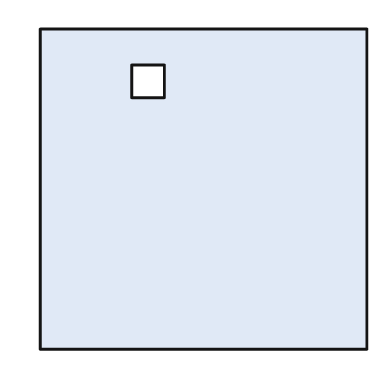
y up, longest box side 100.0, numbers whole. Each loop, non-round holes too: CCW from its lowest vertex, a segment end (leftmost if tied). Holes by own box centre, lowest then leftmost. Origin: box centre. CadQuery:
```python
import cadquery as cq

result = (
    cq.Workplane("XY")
    .moveTo(-50.0, -49.0)
    .lineTo(50.0, -49.0)
    .lineTo(50.0, 49.0)
    .lineTo(-50.0, 49.0)
    .close()
    .moveTo(-22.0, 28.0)
    .lineTo(-12.0, 28.0)
    .lineTo(-12.0, 38.0)
    .lineTo(-22.0, 38.0)
    .close()
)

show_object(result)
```